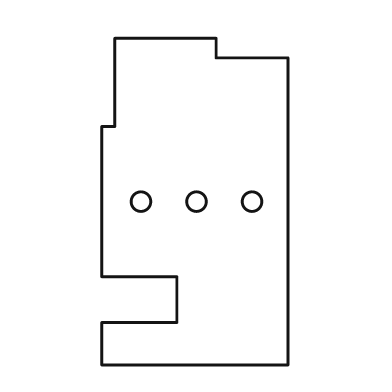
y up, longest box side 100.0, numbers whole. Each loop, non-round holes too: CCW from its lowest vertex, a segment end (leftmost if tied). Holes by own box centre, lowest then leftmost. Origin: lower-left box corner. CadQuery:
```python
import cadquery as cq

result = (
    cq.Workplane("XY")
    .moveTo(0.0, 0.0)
    .lineTo(57.0, 0.0)
    .lineTo(57.0, 94.0)
    .lineTo(35.0, 94.0)
    .lineTo(35.0, 100.0)
    .lineTo(4.0, 100.0)
    .lineTo(4.0, 73.0)
    .lineTo(0.0, 73.0)
    .lineTo(0.0, 27.0)
    .lineTo(23.0, 27.0)
    .lineTo(23.0, 13.0)
    .lineTo(0.0, 13.0)
    .close()
    .moveTo(12.0, 50.0)
    .circle(3.0)
    .moveTo(29.0, 50.0)
    .circle(3.0)
    .moveTo(46.0, 50.0)
    .circle(3.0)
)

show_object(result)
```